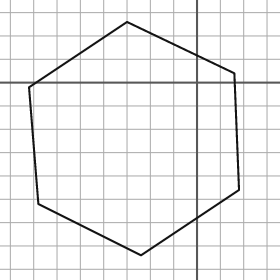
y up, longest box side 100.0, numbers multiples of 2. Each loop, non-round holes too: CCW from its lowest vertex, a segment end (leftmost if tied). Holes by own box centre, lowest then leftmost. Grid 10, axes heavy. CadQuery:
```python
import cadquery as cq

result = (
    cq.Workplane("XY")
    .moveTo(-24.0, -74.0)
    .lineTo(18.0, -46.0)
    .lineTo(16.0, 4.0)
    .lineTo(-30.0, 26.0)
    .lineTo(-72.0, -2.0)
    .lineTo(-68.0, -52.0)
    .close()
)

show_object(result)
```